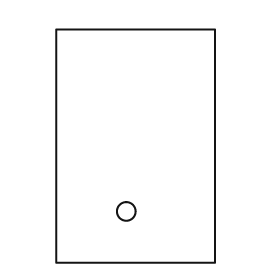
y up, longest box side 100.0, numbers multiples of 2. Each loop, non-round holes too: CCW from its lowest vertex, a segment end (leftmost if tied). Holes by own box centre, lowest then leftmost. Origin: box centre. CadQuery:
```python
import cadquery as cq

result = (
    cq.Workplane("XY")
    .moveTo(-34.0, -50.0)
    .lineTo(34.0, -50.0)
    .lineTo(34.0, 50.0)
    .lineTo(-34.0, 50.0)
    .close()
    .moveTo(-4.0, -28.0)
    .circle(4.0)
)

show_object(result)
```